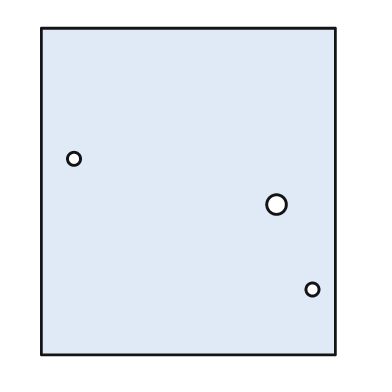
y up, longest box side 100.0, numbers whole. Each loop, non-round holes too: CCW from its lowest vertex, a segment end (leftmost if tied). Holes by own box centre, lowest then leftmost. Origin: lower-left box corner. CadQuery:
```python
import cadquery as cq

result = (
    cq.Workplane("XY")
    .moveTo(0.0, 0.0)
    .lineTo(90.0, 0.0)
    .lineTo(90.0, 100.0)
    .lineTo(0.0, 100.0)
    .close()
    .moveTo(83.0, 20.0)
    .circle(2.0)
    .moveTo(72.0, 46.0)
    .circle(3.0)
    .moveTo(10.0, 60.0)
    .circle(2.0)
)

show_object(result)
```